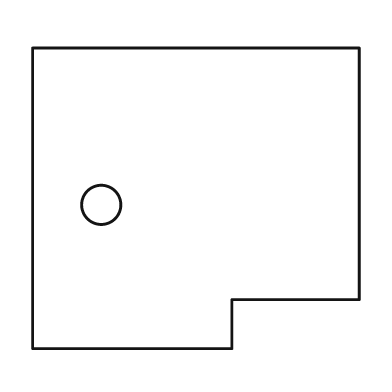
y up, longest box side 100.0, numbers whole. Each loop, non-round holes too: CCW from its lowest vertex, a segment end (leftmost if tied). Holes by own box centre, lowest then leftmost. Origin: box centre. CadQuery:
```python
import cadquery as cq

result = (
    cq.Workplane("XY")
    .moveTo(-50.0, -46.0)
    .lineTo(11.0, -46.0)
    .lineTo(11.0, -31.0)
    .lineTo(50.0, -31.0)
    .lineTo(50.0, 46.0)
    .lineTo(-50.0, 46.0)
    .close()
    .moveTo(-29.0, -2.0)
    .circle(6.0)
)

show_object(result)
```